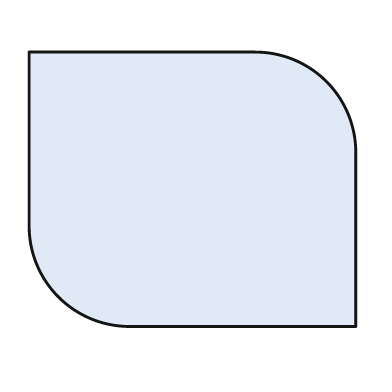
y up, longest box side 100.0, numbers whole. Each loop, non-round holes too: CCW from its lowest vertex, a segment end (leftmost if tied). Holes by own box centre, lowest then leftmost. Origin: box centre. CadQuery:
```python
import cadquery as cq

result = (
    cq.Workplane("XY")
    .moveTo(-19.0, -42.0)
    .lineTo(50.0, -42.0)
    .lineTo(50.0, 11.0)
    .threePointArc((41.0, 33.0), (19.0, 42.0))
    .lineTo(-50.0, 42.0)
    .lineTo(-50.0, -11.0)
    .threePointArc((-41.0, -33.0), (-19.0, -42.0))
    .close()
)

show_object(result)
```